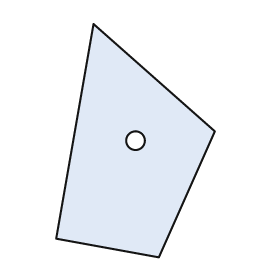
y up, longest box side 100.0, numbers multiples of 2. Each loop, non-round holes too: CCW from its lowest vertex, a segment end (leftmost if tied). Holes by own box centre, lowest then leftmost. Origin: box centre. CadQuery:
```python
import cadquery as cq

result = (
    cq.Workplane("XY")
    .moveTo(10.0, -50.0)
    .lineTo(34.0, 4.0)
    .lineTo(-18.0, 50.0)
    .lineTo(-34.0, -42.0)
    .close()
    .moveTo(0.0, 0.0)
    .circle(4.0)
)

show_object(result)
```